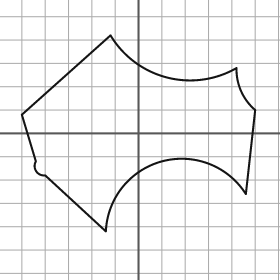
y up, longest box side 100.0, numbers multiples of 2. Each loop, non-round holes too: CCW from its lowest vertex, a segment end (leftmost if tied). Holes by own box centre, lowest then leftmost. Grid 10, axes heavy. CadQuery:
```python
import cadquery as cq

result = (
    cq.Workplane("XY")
    .moveTo(-14.0, -42.0)
    .threePointArc((10.0, -12.0), (46.0, -26.0))
    .lineTo(50.0, 10.0)
    .threePointArc((44.0, 18.0), (42.0, 28.0))
    .threePointArc((12.0, 24.0), (-12.0, 42.0))
    .lineTo(-50.0, 8.0)
    .lineTo(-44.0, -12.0)
    .threePointArc((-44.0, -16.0), (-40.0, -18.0))
    .close()
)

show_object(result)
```